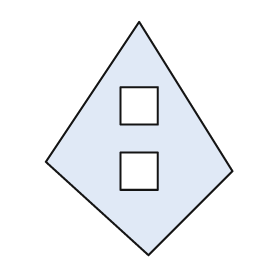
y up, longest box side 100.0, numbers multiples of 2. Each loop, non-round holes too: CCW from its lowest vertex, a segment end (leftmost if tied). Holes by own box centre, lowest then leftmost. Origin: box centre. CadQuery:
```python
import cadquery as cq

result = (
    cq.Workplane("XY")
    .moveTo(4.0, -50.0)
    .lineTo(40.0, -14.0)
    .lineTo(0.0, 50.0)
    .lineTo(-40.0, -10.0)
    .close()
    .moveTo(-8.0, -22.0)
    .lineTo(8.0, -22.0)
    .lineTo(8.0, -6.0)
    .lineTo(-8.0, -6.0)
    .close()
    .moveTo(-8.0, 6.0)
    .lineTo(8.0, 6.0)
    .lineTo(8.0, 22.0)
    .lineTo(-8.0, 22.0)
    .close()
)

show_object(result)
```